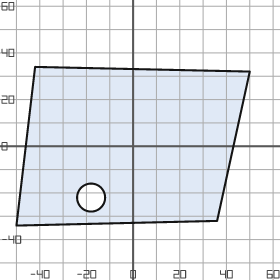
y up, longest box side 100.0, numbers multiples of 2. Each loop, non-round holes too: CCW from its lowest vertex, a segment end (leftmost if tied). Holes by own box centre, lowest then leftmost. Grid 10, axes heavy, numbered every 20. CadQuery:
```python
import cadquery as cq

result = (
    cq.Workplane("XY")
    .moveTo(-50.0, -34.0)
    .lineTo(36.0, -32.0)
    .lineTo(50.0, 32.0)
    .lineTo(-42.0, 34.0)
    .close()
    .moveTo(-18.0, -22.0)
    .circle(6.0)
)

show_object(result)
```